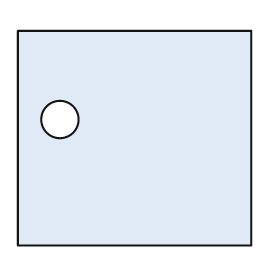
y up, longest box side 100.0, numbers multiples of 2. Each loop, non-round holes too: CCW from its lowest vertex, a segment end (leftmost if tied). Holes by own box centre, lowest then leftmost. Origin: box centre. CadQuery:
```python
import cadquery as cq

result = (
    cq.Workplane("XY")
    .moveTo(-50.0, -46.0)
    .lineTo(50.0, -46.0)
    .lineTo(50.0, 46.0)
    .lineTo(-50.0, 46.0)
    .close()
    .moveTo(-32.0, 8.0)
    .circle(8.0)
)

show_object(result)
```